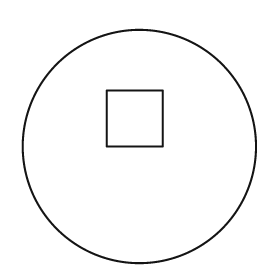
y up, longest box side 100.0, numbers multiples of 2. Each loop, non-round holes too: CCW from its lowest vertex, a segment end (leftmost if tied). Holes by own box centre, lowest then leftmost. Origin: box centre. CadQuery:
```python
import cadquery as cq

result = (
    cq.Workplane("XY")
    .moveTo(0.0, 0.0)
    .circle(50.0)
    .moveTo(-14.0, 0.0)
    .lineTo(10.0, 0.0)
    .lineTo(10.0, 24.0)
    .lineTo(-14.0, 24.0)
    .close()
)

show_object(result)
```